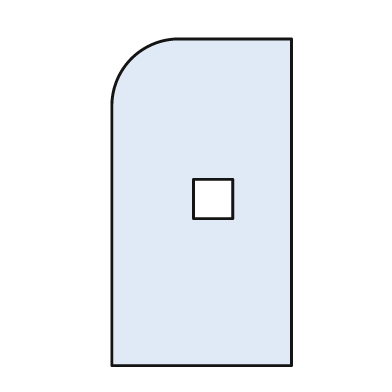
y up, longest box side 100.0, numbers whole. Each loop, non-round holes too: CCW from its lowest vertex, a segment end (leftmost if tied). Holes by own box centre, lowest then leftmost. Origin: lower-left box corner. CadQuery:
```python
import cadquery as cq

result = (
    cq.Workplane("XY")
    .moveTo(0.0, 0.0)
    .lineTo(55.0, 0.0)
    .lineTo(55.0, 100.0)
    .lineTo(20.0, 100.0)
    .threePointArc((6.0, 94.0), (0.0, 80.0))
    .close()
    .moveTo(25.0, 45.0)
    .lineTo(37.0, 45.0)
    .lineTo(37.0, 57.0)
    .lineTo(25.0, 57.0)
    .close()
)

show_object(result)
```